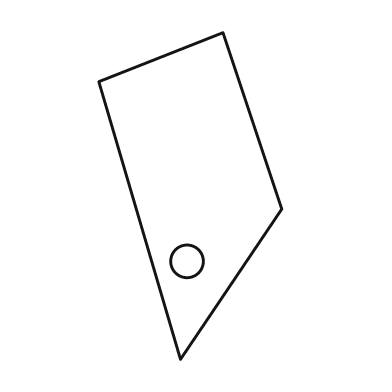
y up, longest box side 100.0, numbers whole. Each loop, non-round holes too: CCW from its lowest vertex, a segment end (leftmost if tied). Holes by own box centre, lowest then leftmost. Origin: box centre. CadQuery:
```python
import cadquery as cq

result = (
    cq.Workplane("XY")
    .moveTo(-3.0, -50.0)
    .lineTo(28.0, -4.0)
    .lineTo(10.0, 50.0)
    .lineTo(-28.0, 35.0)
    .close()
    .moveTo(-1.0, -20.0)
    .circle(5.0)
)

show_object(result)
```